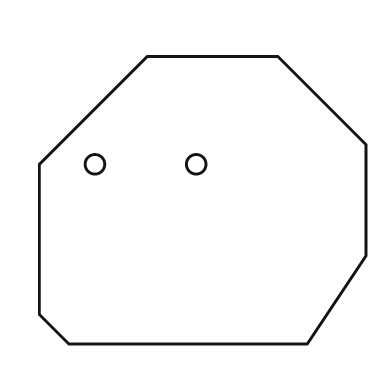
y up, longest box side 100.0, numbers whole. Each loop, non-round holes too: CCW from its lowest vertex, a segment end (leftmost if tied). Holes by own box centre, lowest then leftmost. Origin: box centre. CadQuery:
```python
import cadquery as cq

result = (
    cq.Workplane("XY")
    .moveTo(-41.0, -44.0)
    .lineTo(32.0, -44.0)
    .lineTo(50.0, -17.0)
    .lineTo(50.0, 17.0)
    .lineTo(23.0, 44.0)
    .lineTo(-17.0, 44.0)
    .lineTo(-50.0, 11.0)
    .lineTo(-50.0, -35.0)
    .close()
    .moveTo(-33.0, 11.0)
    .circle(3.0)
    .moveTo(-2.0, 11.0)
    .circle(3.0)
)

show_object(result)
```